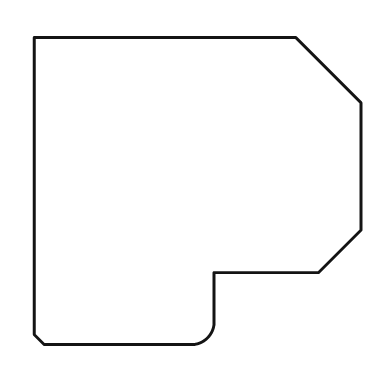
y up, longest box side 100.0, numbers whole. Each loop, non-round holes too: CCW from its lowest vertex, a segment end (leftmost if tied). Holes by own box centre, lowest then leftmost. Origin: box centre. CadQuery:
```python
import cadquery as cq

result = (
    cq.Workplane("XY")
    .moveTo(-47.0, -47.0)
    .lineTo(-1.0, -47.0)
    .threePointArc((3.0, -45.0), (5.0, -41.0))
    .lineTo(5.0, -25.0)
    .lineTo(37.0, -25.0)
    .lineTo(50.0, -12.0)
    .lineTo(50.0, 27.0)
    .lineTo(30.0, 47.0)
    .lineTo(-50.0, 47.0)
    .lineTo(-50.0, -44.0)
    .close()
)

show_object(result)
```